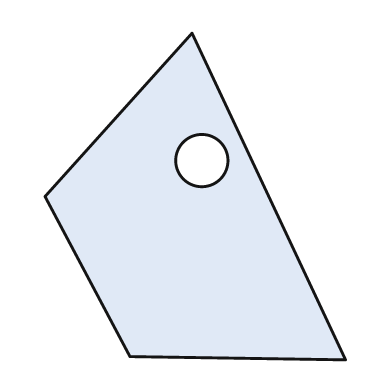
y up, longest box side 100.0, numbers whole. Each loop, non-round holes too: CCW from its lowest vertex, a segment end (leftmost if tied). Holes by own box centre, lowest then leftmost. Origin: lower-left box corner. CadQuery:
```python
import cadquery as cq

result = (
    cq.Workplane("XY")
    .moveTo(92.0, 0.0)
    .lineTo(45.0, 100.0)
    .lineTo(0.0, 50.0)
    .lineTo(26.0, 1.0)
    .close()
    .moveTo(48.0, 61.0)
    .circle(8.0)
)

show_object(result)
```